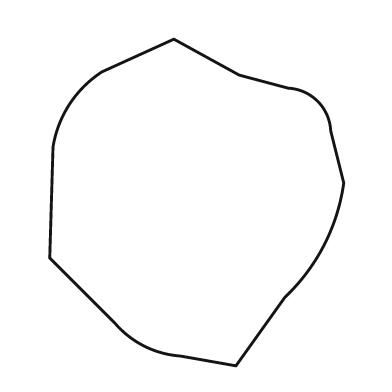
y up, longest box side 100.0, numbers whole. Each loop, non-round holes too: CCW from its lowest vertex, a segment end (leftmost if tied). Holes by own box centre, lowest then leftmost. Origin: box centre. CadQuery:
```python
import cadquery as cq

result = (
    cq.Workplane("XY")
    .moveTo(12.0, -50.0)
    .lineTo(27.0, -29.0)
    .threePointArc((39.0, -13.0), (45.0, 6.0))
    .lineTo(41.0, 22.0)
    .threePointArc((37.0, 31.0), (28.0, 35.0))
    .lineTo(13.0, 39.0)
    .lineTo(-7.0, 50.0)
    .lineTo(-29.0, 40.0)
    .threePointArc((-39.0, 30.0), (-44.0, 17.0))
    .lineTo(-45.0, -17.0)
    .lineTo(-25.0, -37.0)
    .threePointArc((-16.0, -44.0), (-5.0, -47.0))
    .close()
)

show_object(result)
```